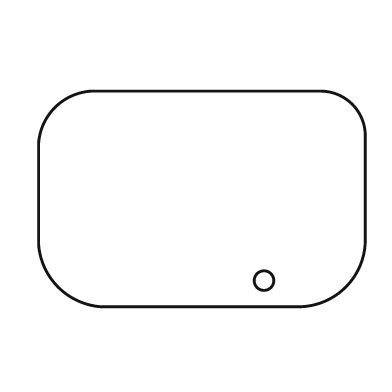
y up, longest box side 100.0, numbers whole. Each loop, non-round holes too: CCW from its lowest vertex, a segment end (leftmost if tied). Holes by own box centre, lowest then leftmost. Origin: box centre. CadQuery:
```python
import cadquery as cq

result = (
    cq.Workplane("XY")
    .moveTo(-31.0, -33.0)
    .lineTo(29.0, -33.0)
    .threePointArc((44.0, -27.0), (50.0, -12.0))
    .lineTo(50.0, 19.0)
    .threePointArc((46.0, 29.0), (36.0, 33.0))
    .lineTo(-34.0, 33.0)
    .threePointArc((-45.0, 28.0), (-50.0, 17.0))
    .lineTo(-50.0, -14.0)
    .threePointArc((-44.0, -27.0), (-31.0, -33.0))
    .close()
    .moveTo(19.0, -25.0)
    .circle(3.0)
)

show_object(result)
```